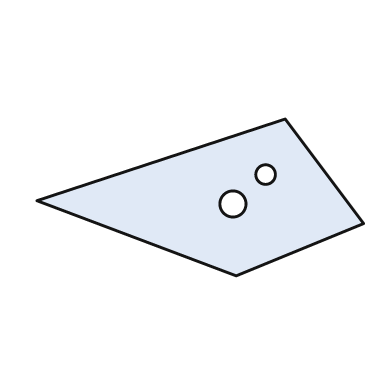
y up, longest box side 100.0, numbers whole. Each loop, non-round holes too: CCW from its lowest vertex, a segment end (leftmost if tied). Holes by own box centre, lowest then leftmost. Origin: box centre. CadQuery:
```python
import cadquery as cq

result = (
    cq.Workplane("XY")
    .moveTo(11.0, -24.0)
    .lineTo(50.0, -8.0)
    .lineTo(26.0, 24.0)
    .lineTo(-50.0, -1.0)
    .close()
    .moveTo(10.0, -2.0)
    .circle(4.0)
    .moveTo(20.0, 7.0)
    .circle(3.0)
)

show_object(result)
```